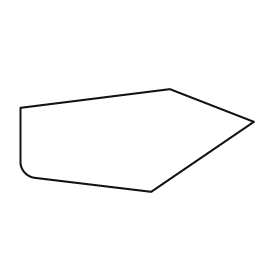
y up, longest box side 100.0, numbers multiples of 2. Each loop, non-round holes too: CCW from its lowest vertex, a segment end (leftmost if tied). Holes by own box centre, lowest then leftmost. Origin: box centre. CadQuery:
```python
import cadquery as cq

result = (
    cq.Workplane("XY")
    .moveTo(6.0, -22.0)
    .lineTo(50.0, 8.0)
    .lineTo(14.0, 22.0)
    .lineTo(-50.0, 14.0)
    .lineTo(-50.0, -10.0)
    .threePointArc((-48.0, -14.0), (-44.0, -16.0))
    .close()
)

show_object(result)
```